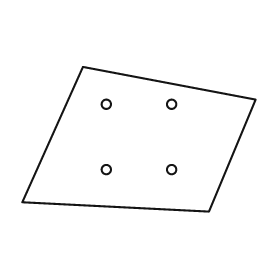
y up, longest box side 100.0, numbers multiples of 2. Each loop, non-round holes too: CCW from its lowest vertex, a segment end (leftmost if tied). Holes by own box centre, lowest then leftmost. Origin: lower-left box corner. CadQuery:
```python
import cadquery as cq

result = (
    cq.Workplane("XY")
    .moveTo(80.0, 0.0)
    .lineTo(100.0, 48.0)
    .lineTo(26.0, 62.0)
    .lineTo(0.0, 4.0)
    .close()
    .moveTo(36.0, 18.0)
    .circle(2.0)
    .moveTo(64.0, 18.0)
    .circle(2.0)
    .moveTo(36.0, 46.0)
    .circle(2.0)
    .moveTo(64.0, 46.0)
    .circle(2.0)
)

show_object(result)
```